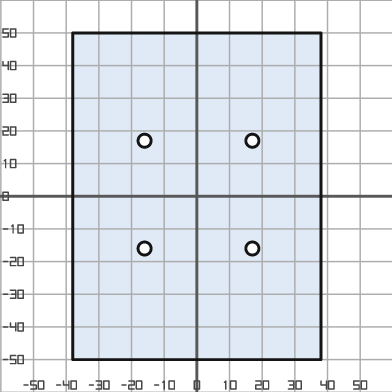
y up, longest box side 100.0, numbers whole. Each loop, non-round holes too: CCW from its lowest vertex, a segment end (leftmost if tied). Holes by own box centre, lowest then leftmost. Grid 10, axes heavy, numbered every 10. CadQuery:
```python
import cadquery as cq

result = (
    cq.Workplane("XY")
    .moveTo(-38.0, -50.0)
    .lineTo(38.0, -50.0)
    .lineTo(38.0, 50.0)
    .lineTo(-38.0, 50.0)
    .close()
    .moveTo(-16.0, -16.0)
    .circle(2.0)
    .moveTo(17.0, -16.0)
    .circle(2.0)
    .moveTo(-16.0, 17.0)
    .circle(2.0)
    .moveTo(17.0, 17.0)
    .circle(2.0)
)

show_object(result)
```